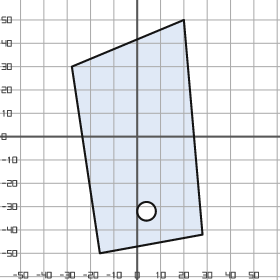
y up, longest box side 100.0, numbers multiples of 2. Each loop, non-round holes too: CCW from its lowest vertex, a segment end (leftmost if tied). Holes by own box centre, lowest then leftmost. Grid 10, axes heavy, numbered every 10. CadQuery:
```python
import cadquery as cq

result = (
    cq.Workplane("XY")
    .moveTo(-16.0, -50.0)
    .lineTo(28.0, -42.0)
    .lineTo(20.0, 50.0)
    .lineTo(-28.0, 30.0)
    .close()
    .moveTo(4.0, -32.0)
    .circle(4.0)
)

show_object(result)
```